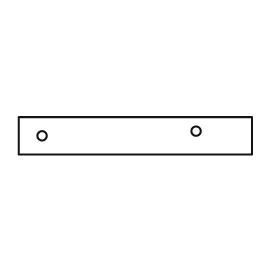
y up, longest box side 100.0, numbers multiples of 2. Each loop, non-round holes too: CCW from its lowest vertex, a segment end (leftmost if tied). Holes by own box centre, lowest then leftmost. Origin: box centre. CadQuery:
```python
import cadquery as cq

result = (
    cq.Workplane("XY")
    .moveTo(-50.0, -8.0)
    .lineTo(50.0, -8.0)
    .lineTo(50.0, 8.0)
    .lineTo(-50.0, 8.0)
    .close()
    .moveTo(-40.0, 0.0)
    .circle(2.0)
    .moveTo(26.0, 2.0)
    .circle(2.0)
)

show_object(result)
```